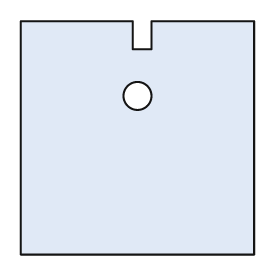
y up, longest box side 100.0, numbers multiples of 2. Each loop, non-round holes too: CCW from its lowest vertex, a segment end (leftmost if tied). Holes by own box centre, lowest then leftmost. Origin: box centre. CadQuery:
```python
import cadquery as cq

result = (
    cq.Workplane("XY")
    .moveTo(-50.0, -50.0)
    .lineTo(50.0, -50.0)
    .lineTo(50.0, 50.0)
    .lineTo(6.0, 50.0)
    .lineTo(6.0, 38.0)
    .lineTo(-2.0, 38.0)
    .lineTo(-2.0, 50.0)
    .lineTo(-50.0, 50.0)
    .close()
    .moveTo(0.0, 18.0)
    .circle(6.0)
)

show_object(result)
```